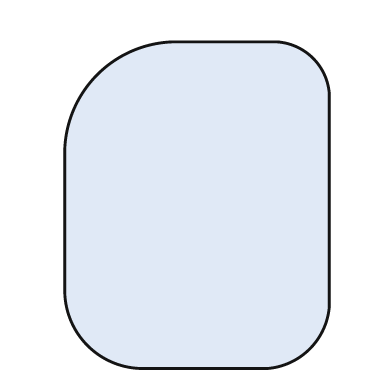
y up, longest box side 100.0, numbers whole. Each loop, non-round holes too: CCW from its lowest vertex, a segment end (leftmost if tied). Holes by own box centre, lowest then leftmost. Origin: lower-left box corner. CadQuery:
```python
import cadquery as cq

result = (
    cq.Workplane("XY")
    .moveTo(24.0, 0.0)
    .lineTo(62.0, 0.0)
    .threePointArc((75.0, 6.0), (81.0, 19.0))
    .lineTo(81.0, 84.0)
    .threePointArc((76.0, 95.0), (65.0, 100.0))
    .lineTo(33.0, 100.0)
    .threePointArc((10.0, 90.0), (0.0, 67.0))
    .lineTo(0.0, 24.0)
    .threePointArc((7.0, 7.0), (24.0, 0.0))
    .close()
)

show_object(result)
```